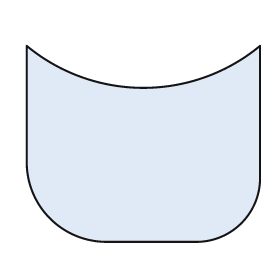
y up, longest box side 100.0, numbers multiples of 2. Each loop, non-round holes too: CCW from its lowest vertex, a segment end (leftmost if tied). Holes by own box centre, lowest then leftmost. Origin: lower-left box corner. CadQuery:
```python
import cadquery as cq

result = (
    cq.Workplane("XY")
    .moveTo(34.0, 0.0)
    .lineTo(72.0, 0.0)
    .threePointArc((92.0, 8.0), (100.0, 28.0))
    .lineTo(100.0, 84.0)
    .threePointArc((50.0, 66.0), (0.0, 84.0))
    .lineTo(0.0, 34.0)
    .threePointArc((10.0, 10.0), (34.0, 0.0))
    .close()
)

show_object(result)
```